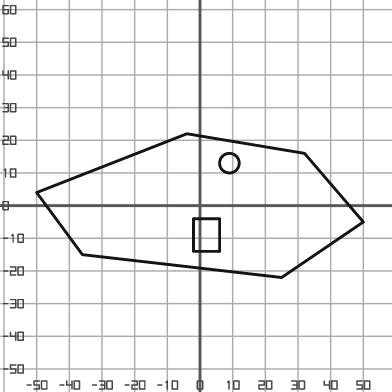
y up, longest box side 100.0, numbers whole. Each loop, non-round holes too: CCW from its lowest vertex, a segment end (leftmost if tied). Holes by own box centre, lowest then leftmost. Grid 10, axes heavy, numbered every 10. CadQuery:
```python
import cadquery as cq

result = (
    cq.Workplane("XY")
    .moveTo(25.0, -22.0)
    .lineTo(50.0, -5.0)
    .lineTo(32.0, 16.0)
    .lineTo(-4.0, 22.0)
    .lineTo(-50.0, 4.0)
    .lineTo(-36.0, -15.0)
    .close()
    .moveTo(-2.0, -14.0)
    .lineTo(6.0, -14.0)
    .lineTo(6.0, -4.0)
    .lineTo(-2.0, -4.0)
    .close()
    .moveTo(9.0, 13.0)
    .circle(3.0)
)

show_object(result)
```